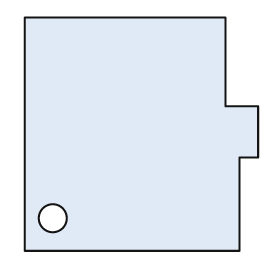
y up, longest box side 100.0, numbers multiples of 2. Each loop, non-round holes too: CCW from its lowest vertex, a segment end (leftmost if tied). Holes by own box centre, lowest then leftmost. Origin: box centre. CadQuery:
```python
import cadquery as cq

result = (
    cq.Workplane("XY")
    .moveTo(-50.0, -50.0)
    .lineTo(42.0, -50.0)
    .lineTo(42.0, -10.0)
    .lineTo(50.0, -10.0)
    .lineTo(50.0, 12.0)
    .lineTo(36.0, 12.0)
    .lineTo(36.0, 50.0)
    .lineTo(-50.0, 50.0)
    .close()
    .moveTo(-38.0, -36.0)
    .circle(6.0)
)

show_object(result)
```